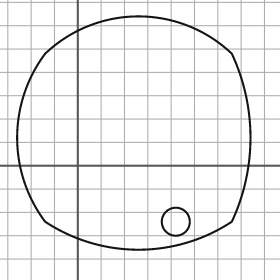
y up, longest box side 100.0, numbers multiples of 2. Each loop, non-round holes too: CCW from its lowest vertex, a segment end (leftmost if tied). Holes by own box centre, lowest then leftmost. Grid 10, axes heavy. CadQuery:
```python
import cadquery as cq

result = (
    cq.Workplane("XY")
    .moveTo(-14.0, -24.0)
    .threePointArc((26.0, -36.0), (66.0, -24.0))
    .threePointArc((74.0, 12.0), (66.0, 48.0))
    .threePointArc((26.0, 64.0), (-14.0, 48.0))
    .threePointArc((-26.0, 12.0), (-14.0, -24.0))
    .close()
    .moveTo(42.0, -24.0)
    .circle(6.0)
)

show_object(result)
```